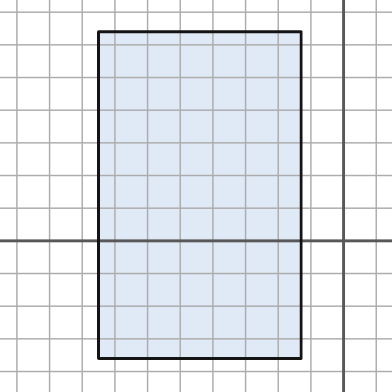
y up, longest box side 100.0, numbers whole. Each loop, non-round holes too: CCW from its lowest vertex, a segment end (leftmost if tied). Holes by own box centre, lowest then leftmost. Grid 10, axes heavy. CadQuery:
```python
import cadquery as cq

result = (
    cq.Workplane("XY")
    .moveTo(-75.0, -36.0)
    .lineTo(-13.0, -36.0)
    .lineTo(-13.0, 64.0)
    .lineTo(-75.0, 64.0)
    .close()
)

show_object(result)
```